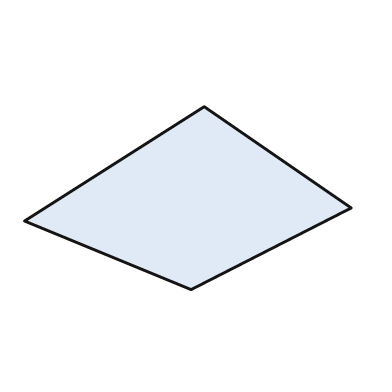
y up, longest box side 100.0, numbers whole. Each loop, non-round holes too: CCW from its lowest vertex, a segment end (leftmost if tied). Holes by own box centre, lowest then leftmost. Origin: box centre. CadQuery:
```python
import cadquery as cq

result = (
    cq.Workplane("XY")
    .moveTo(1.0, -28.0)
    .lineTo(50.0, -3.0)
    .lineTo(5.0, 28.0)
    .lineTo(-50.0, -7.0)
    .close()
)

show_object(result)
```